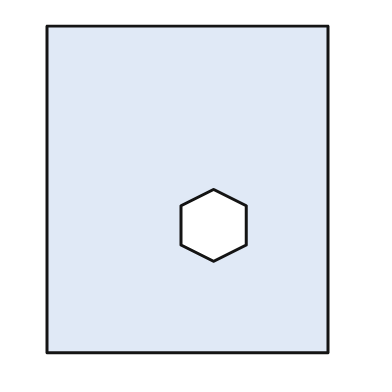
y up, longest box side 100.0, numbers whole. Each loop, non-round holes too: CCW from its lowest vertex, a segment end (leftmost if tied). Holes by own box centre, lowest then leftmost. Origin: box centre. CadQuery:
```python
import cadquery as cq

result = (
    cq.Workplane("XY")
    .moveTo(-43.0, -50.0)
    .lineTo(43.0, -50.0)
    .lineTo(43.0, 50.0)
    .lineTo(-43.0, 50.0)
    .close()
    .moveTo(8.0, -22.0)
    .lineTo(18.0, -17.0)
    .lineTo(18.0, -5.0)
    .lineTo(8.0, 0.0)
    .lineTo(-2.0, -5.0)
    .lineTo(-2.0, -17.0)
    .close()
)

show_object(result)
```